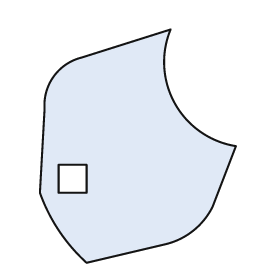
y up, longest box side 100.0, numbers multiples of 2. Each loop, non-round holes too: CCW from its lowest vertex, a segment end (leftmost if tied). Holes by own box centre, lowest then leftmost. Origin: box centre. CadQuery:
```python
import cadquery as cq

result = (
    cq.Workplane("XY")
    .moveTo(-22.0, -50.0)
    .lineTo(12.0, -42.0)
    .threePointArc((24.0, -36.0), (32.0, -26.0))
    .lineTo(42.0, 0.0)
    .threePointArc((16.0, 18.0), (14.0, 50.0))
    .lineTo(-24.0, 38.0)
    .threePointArc((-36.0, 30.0), (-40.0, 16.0))
    .lineTo(-42.0, -20.0)
    .threePointArc((-34.0, -36.0), (-22.0, -50.0))
    .close()
    .moveTo(-34.0, -20.0)
    .lineTo(-22.0, -20.0)
    .lineTo(-22.0, -8.0)
    .lineTo(-34.0, -8.0)
    .close()
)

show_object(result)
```